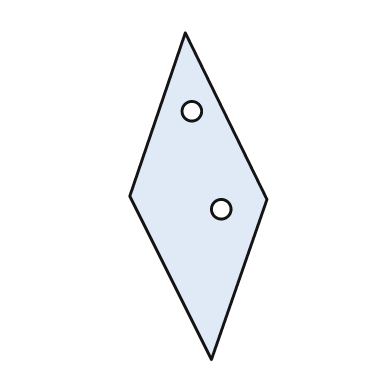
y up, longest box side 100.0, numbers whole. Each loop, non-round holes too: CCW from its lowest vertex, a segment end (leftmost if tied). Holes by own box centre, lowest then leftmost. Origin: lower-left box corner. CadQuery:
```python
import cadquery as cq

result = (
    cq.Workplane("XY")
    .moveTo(25.0, 0.0)
    .lineTo(42.0, 49.0)
    .lineTo(17.0, 100.0)
    .lineTo(0.0, 50.0)
    .close()
    .moveTo(28.0, 46.0)
    .circle(3.0)
    .moveTo(19.0, 76.0)
    .circle(3.0)
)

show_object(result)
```